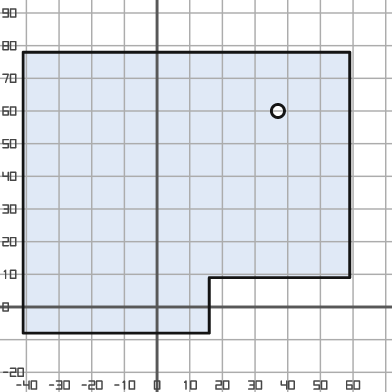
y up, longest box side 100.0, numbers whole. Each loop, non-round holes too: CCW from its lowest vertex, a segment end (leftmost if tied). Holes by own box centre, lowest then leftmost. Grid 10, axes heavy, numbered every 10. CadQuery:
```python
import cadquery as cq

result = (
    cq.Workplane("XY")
    .moveTo(-41.0, -8.0)
    .lineTo(16.0, -8.0)
    .lineTo(16.0, 9.0)
    .lineTo(59.0, 9.0)
    .lineTo(59.0, 78.0)
    .lineTo(-41.0, 78.0)
    .close()
    .moveTo(37.0, 60.0)
    .circle(2.0)
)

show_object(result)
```